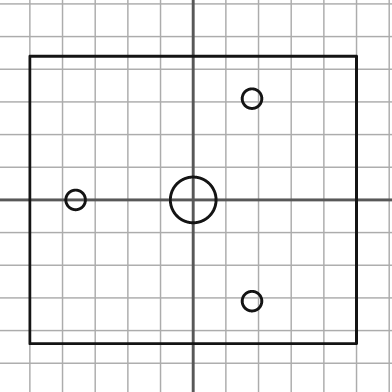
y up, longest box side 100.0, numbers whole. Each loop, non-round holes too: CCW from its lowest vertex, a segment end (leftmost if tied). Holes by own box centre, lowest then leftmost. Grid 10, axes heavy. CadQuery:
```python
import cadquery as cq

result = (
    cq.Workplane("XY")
    .moveTo(-50.0, -44.0)
    .lineTo(50.0, -44.0)
    .lineTo(50.0, 44.0)
    .lineTo(-50.0, 44.0)
    .close()
    .moveTo(18.0, -31.0)
    .circle(3.0)
    .moveTo(-36.0, 0.0)
    .circle(3.0)
    .moveTo(0.0, 0.0)
    .circle(7.0)
    .moveTo(18.0, 31.0)
    .circle(3.0)
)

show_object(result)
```